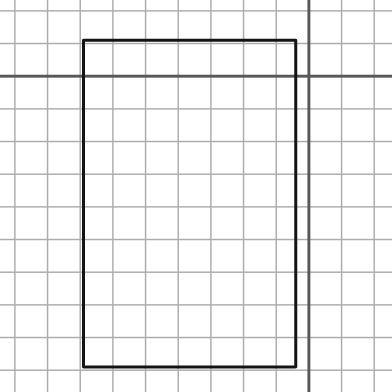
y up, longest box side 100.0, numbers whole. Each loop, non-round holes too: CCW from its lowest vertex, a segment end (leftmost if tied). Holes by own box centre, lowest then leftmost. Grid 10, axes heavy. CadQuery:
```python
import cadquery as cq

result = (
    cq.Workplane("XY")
    .moveTo(-69.0, -89.0)
    .lineTo(-4.0, -89.0)
    .lineTo(-4.0, 11.0)
    .lineTo(-69.0, 11.0)
    .close()
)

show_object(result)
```